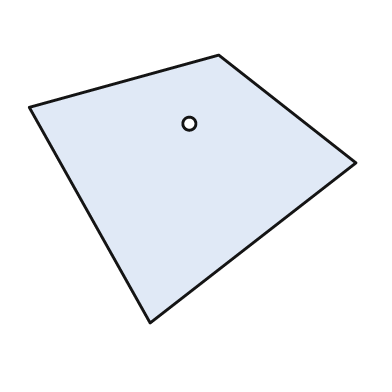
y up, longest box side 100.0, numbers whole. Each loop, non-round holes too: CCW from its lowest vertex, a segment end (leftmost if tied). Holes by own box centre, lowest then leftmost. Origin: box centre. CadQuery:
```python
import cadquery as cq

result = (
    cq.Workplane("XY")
    .moveTo(-13.0, -41.0)
    .lineTo(50.0, 8.0)
    .lineTo(8.0, 41.0)
    .lineTo(-50.0, 25.0)
    .close()
    .moveTo(-1.0, 20.0)
    .circle(2.0)
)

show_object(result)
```